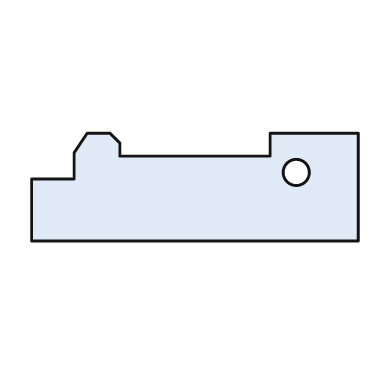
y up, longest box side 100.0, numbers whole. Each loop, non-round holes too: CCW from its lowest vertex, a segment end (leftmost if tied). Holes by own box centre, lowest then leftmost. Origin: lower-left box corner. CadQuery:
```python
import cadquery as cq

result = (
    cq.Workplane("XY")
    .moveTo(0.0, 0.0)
    .lineTo(100.0, 0.0)
    .lineTo(100.0, 33.0)
    .lineTo(73.0, 33.0)
    .lineTo(73.0, 26.0)
    .lineTo(27.0, 26.0)
    .lineTo(27.0, 30.0)
    .lineTo(24.0, 33.0)
    .lineTo(17.0, 33.0)
    .lineTo(13.0, 27.0)
    .lineTo(13.0, 19.0)
    .lineTo(0.0, 19.0)
    .close()
    .moveTo(81.0, 21.0)
    .circle(4.0)
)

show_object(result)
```